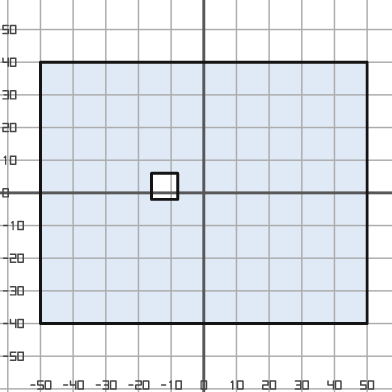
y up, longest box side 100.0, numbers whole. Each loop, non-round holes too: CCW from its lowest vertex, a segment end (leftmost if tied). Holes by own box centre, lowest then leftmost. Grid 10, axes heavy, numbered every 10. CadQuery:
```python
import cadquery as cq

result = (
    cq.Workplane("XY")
    .moveTo(-50.0, -40.0)
    .lineTo(50.0, -40.0)
    .lineTo(50.0, 40.0)
    .lineTo(-50.0, 40.0)
    .close()
    .moveTo(-16.0, -2.0)
    .lineTo(-8.0, -2.0)
    .lineTo(-8.0, 6.0)
    .lineTo(-16.0, 6.0)
    .close()
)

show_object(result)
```